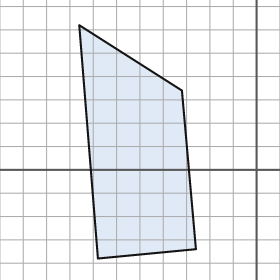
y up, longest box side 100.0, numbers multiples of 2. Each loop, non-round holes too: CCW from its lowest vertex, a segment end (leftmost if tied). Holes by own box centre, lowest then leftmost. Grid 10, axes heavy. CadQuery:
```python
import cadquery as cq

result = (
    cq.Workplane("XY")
    .moveTo(-68.0, -38.0)
    .lineTo(-26.0, -34.0)
    .lineTo(-32.0, 34.0)
    .lineTo(-76.0, 62.0)
    .close()
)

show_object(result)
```